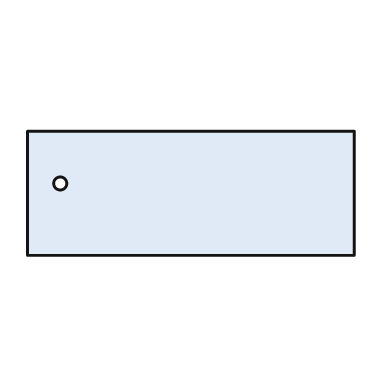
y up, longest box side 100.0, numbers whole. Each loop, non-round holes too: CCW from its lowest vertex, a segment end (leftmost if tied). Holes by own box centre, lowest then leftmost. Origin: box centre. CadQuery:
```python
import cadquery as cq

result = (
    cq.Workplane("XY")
    .moveTo(-50.0, -19.0)
    .lineTo(50.0, -19.0)
    .lineTo(50.0, 19.0)
    .lineTo(-50.0, 19.0)
    .close()
    .moveTo(-40.0, 3.0)
    .circle(2.0)
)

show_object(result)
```